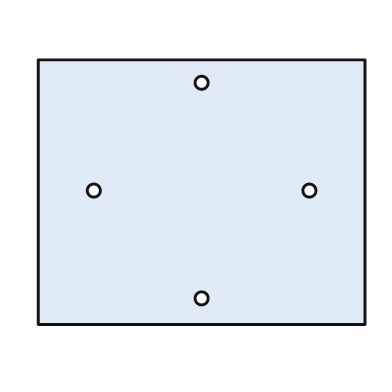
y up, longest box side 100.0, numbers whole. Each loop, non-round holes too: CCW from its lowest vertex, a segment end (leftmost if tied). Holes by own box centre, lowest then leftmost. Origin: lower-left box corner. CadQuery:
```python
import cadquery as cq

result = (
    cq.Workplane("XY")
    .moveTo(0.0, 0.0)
    .lineTo(100.0, 0.0)
    .lineTo(100.0, 81.0)
    .lineTo(0.0, 81.0)
    .close()
    .moveTo(50.0, 8.0)
    .circle(2.0)
    .moveTo(17.0, 41.0)
    .circle(2.0)
    .moveTo(83.0, 41.0)
    .circle(2.0)
    .moveTo(50.0, 74.0)
    .circle(2.0)
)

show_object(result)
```